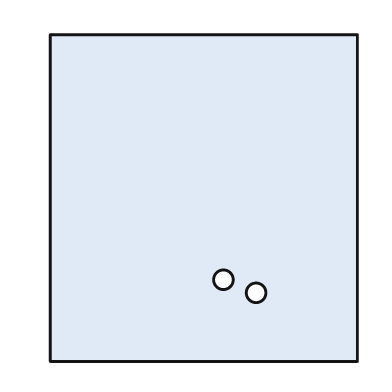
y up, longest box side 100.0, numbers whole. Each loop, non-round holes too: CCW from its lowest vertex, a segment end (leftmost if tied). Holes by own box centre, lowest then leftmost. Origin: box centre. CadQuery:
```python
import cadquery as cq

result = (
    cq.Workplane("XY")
    .moveTo(-47.0, -50.0)
    .lineTo(47.0, -50.0)
    .lineTo(47.0, 50.0)
    .lineTo(-47.0, 50.0)
    .close()
    .moveTo(16.0, -29.0)
    .circle(3.0)
    .moveTo(6.0, -25.0)
    .circle(3.0)
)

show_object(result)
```